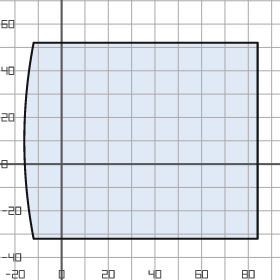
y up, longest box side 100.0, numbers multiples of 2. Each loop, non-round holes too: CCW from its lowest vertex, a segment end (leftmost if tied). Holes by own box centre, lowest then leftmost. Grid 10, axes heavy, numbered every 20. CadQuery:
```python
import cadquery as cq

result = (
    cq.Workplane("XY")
    .moveTo(-12.0, -32.0)
    .lineTo(84.0, -32.0)
    .lineTo(84.0, 52.0)
    .lineTo(-12.0, 52.0)
    .threePointArc((-16.0, 10.0), (-12.0, -32.0))
    .close()
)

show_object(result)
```